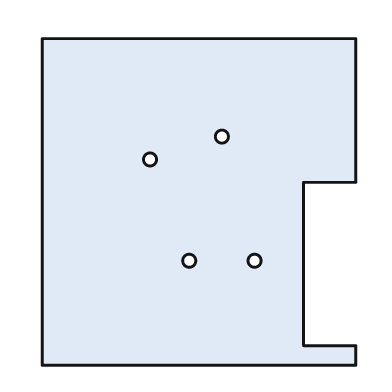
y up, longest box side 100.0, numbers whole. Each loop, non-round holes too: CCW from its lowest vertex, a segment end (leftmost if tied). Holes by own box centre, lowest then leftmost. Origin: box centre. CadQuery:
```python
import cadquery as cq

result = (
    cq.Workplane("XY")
    .moveTo(-48.0, -50.0)
    .lineTo(48.0, -50.0)
    .lineTo(48.0, -44.0)
    .lineTo(32.0, -44.0)
    .lineTo(32.0, 6.0)
    .lineTo(48.0, 6.0)
    .lineTo(48.0, 50.0)
    .lineTo(-48.0, 50.0)
    .close()
    .moveTo(-3.0, -18.0)
    .circle(2.0)
    .moveTo(17.0, -18.0)
    .circle(2.0)
    .moveTo(-15.0, 13.0)
    .circle(2.0)
    .moveTo(7.0, 20.0)
    .circle(2.0)
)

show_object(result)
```